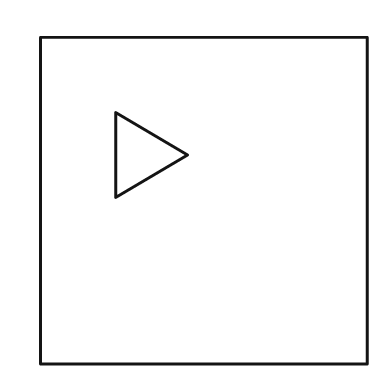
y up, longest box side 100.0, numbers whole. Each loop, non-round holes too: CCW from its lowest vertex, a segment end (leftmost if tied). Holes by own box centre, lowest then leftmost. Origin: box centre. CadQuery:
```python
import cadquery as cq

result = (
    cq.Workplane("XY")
    .moveTo(-50.0, -50.0)
    .lineTo(50.0, -50.0)
    .lineTo(50.0, 50.0)
    .lineTo(-50.0, 50.0)
    .close()
    .moveTo(-27.0, 1.0)
    .lineTo(-5.0, 14.0)
    .lineTo(-27.0, 27.0)
    .close()
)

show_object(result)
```